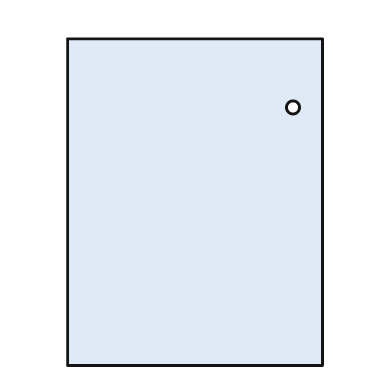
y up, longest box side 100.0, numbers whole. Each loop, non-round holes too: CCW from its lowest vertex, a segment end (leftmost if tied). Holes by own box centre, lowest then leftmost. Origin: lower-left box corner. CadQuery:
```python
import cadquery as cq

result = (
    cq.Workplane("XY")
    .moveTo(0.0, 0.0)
    .lineTo(78.0, 0.0)
    .lineTo(78.0, 100.0)
    .lineTo(0.0, 100.0)
    .close()
    .moveTo(69.0, 79.0)
    .circle(2.0)
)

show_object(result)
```